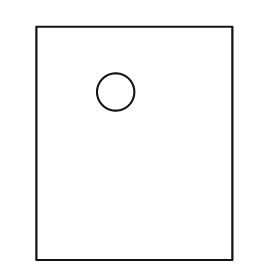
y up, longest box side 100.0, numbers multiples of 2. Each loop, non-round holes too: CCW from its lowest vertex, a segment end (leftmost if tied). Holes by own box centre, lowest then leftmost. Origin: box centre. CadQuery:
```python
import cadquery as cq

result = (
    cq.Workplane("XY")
    .moveTo(-42.0, -50.0)
    .lineTo(42.0, -50.0)
    .lineTo(42.0, 50.0)
    .lineTo(-42.0, 50.0)
    .close()
    .moveTo(-8.0, 22.0)
    .circle(8.0)
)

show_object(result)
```